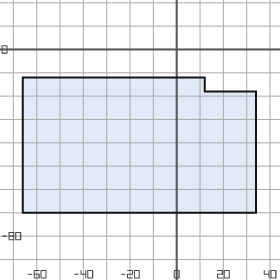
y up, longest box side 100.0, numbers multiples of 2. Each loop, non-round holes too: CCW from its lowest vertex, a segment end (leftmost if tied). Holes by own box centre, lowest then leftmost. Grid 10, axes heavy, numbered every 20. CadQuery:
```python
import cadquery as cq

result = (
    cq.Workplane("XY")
    .moveTo(-66.0, -70.0)
    .lineTo(34.0, -70.0)
    .lineTo(34.0, -18.0)
    .lineTo(12.0, -18.0)
    .lineTo(12.0, -12.0)
    .lineTo(-66.0, -12.0)
    .close()
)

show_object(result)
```